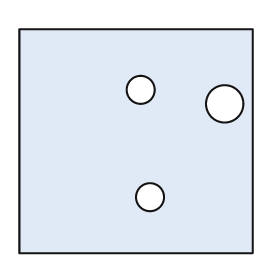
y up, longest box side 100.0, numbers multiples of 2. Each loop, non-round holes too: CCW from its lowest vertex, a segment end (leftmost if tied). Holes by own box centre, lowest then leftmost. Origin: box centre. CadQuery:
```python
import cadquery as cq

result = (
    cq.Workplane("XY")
    .moveTo(-50.0, -48.0)
    .lineTo(50.0, -48.0)
    .lineTo(50.0, 48.0)
    .lineTo(-50.0, 48.0)
    .close()
    .moveTo(6.0, -24.0)
    .circle(6.0)
    .moveTo(38.0, 16.0)
    .circle(8.0)
    .moveTo(2.0, 22.0)
    .circle(6.0)
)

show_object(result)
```